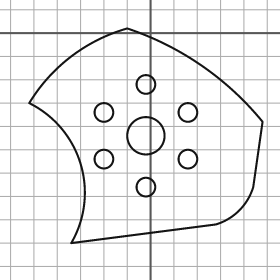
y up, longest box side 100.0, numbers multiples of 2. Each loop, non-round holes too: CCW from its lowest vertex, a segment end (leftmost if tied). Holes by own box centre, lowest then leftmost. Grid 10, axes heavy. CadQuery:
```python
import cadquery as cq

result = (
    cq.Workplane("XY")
    .moveTo(-34.0, -90.0)
    .lineTo(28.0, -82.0)
    .threePointArc((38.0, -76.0), (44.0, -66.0))
    .lineTo(48.0, -38.0)
    .threePointArc((22.0, -14.0), (-10.0, 2.0))
    .threePointArc((-34.0, -10.0), (-52.0, -30.0))
    .threePointArc((-30.0, -56.0), (-34.0, -90.0))
    .close()
    .moveTo(-2.0, -66.0)
    .circle(4.0)
    .moveTo(-20.0, -54.0)
    .circle(4.0)
    .moveTo(16.0, -54.0)
    .circle(4.0)
    .moveTo(-2.0, -44.0)
    .circle(8.0)
    .moveTo(-20.0, -34.0)
    .circle(4.0)
    .moveTo(16.0, -34.0)
    .circle(4.0)
    .moveTo(-2.0, -22.0)
    .circle(4.0)
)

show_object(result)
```